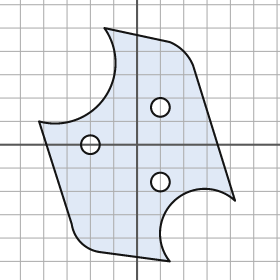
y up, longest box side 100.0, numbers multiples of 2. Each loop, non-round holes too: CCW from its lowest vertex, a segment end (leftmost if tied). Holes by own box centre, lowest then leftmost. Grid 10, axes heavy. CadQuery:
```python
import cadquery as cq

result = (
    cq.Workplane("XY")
    .moveTo(14.0, -50.0)
    .threePointArc((16.0, -24.0), (42.0, -24.0))
    .lineTo(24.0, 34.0)
    .threePointArc((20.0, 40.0), (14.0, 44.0))
    .lineTo(-14.0, 50.0)
    .threePointArc((-14.0, 20.0), (-42.0, 10.0))
    .lineTo(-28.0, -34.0)
    .threePointArc((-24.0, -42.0), (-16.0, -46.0))
    .close()
    .moveTo(10.0, -16.0)
    .circle(4.0)
    .moveTo(-20.0, 0.0)
    .circle(4.0)
    .moveTo(10.0, 16.0)
    .circle(4.0)
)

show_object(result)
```